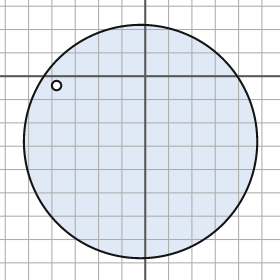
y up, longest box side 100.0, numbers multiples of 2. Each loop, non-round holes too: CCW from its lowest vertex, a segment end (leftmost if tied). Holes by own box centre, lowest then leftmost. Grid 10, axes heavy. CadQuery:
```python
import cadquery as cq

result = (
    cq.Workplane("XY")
    .moveTo(-2.0, -28.0)
    .circle(50.0)
    .moveTo(-38.0, -4.0)
    .circle(2.0)
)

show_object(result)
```